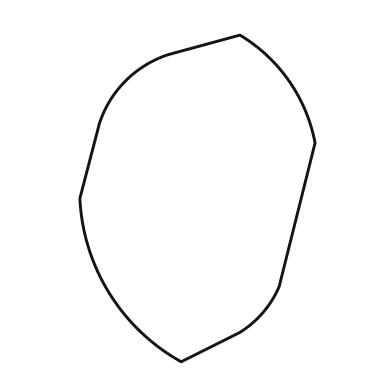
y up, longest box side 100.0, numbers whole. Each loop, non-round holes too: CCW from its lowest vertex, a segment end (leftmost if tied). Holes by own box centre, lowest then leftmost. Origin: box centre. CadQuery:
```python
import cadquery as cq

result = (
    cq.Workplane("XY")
    .moveTo(-5.0, -50.0)
    .lineTo(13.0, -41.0)
    .threePointArc((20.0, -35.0), (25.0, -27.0))
    .lineTo(36.0, 17.0)
    .threePointArc((28.0, 36.0), (13.0, 50.0))
    .lineTo(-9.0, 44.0)
    .threePointArc((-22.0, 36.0), (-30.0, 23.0))
    .lineTo(-36.0, 0.0)
    .threePointArc((-27.0, -29.0), (-5.0, -50.0))
    .close()
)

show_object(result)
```